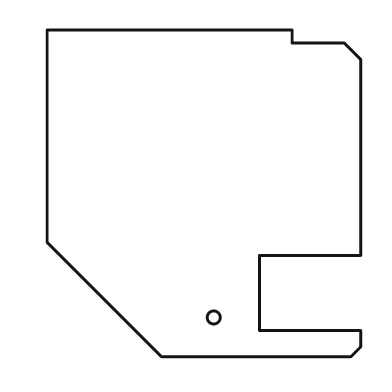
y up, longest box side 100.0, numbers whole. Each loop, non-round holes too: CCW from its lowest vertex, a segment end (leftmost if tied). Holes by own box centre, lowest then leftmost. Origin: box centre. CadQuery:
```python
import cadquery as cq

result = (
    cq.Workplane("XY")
    .moveTo(-13.0, -50.0)
    .lineTo(45.0, -50.0)
    .lineTo(48.0, -47.0)
    .lineTo(48.0, -42.0)
    .lineTo(17.0, -42.0)
    .lineTo(17.0, -19.0)
    .lineTo(48.0, -19.0)
    .lineTo(48.0, 41.0)
    .lineTo(43.0, 46.0)
    .lineTo(27.0, 46.0)
    .lineTo(27.0, 50.0)
    .lineTo(-48.0, 50.0)
    .lineTo(-48.0, -15.0)
    .close()
    .moveTo(3.0, -38.0)
    .circle(2.0)
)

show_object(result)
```